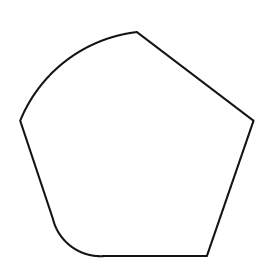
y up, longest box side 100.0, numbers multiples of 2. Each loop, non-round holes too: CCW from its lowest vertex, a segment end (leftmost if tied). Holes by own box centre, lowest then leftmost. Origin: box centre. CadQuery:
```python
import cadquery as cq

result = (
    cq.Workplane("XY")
    .moveTo(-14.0, -48.0)
    .lineTo(30.0, -48.0)
    .lineTo(50.0, 10.0)
    .lineTo(0.0, 48.0)
    .threePointArc((-30.0, 36.0), (-50.0, 10.0))
    .lineTo(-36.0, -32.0)
    .threePointArc((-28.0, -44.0), (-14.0, -48.0))
    .close()
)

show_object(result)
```